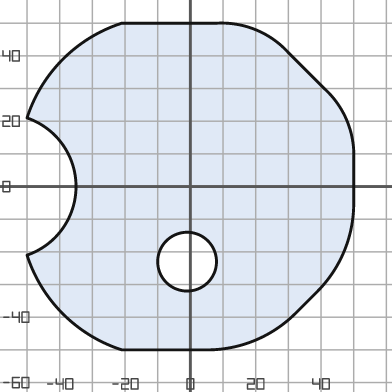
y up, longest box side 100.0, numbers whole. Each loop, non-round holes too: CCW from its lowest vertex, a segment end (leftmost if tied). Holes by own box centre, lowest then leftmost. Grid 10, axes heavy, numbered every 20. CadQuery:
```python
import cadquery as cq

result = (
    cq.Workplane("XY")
    .moveTo(-21.0, -50.0)
    .lineTo(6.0, -50.0)
    .threePointArc((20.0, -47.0), (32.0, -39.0))
    .lineTo(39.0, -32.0)
    .threePointArc((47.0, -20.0), (50.0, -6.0))
    .lineTo(50.0, 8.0)
    .threePointArc((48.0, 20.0), (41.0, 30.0))
    .lineTo(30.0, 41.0)
    .threePointArc((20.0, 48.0), (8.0, 50.0))
    .lineTo(-21.0, 50.0)
    .threePointArc((-39.0, 39.0), (-50.0, 21.0))
    .threePointArc((-35.0, 0.0), (-50.0, -21.0))
    .threePointArc((-39.0, -39.0), (-21.0, -50.0))
    .close()
    .moveTo(-1.0, -23.0)
    .circle(9.0)
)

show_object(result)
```